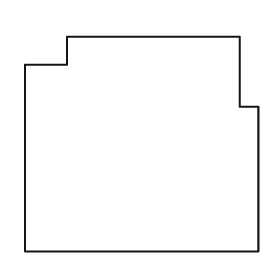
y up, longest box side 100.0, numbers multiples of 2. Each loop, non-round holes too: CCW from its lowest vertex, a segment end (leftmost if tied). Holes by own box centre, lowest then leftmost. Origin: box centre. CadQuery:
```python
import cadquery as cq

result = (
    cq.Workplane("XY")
    .moveTo(-50.0, -46.0)
    .lineTo(50.0, -46.0)
    .lineTo(50.0, 16.0)
    .lineTo(42.0, 16.0)
    .lineTo(42.0, 46.0)
    .lineTo(-32.0, 46.0)
    .lineTo(-32.0, 34.0)
    .lineTo(-50.0, 34.0)
    .close()
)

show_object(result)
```